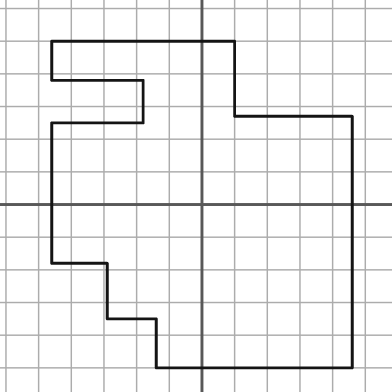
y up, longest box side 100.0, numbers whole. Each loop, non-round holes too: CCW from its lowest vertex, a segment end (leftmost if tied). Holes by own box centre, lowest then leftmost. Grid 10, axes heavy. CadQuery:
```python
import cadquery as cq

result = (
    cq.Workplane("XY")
    .moveTo(-14.0, -50.0)
    .lineTo(46.0, -50.0)
    .lineTo(46.0, 27.0)
    .lineTo(10.0, 27.0)
    .lineTo(10.0, 50.0)
    .lineTo(-46.0, 50.0)
    .lineTo(-46.0, 38.0)
    .lineTo(-18.0, 38.0)
    .lineTo(-18.0, 25.0)
    .lineTo(-46.0, 25.0)
    .lineTo(-46.0, -18.0)
    .lineTo(-29.0, -18.0)
    .lineTo(-29.0, -35.0)
    .lineTo(-14.0, -35.0)
    .close()
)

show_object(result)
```